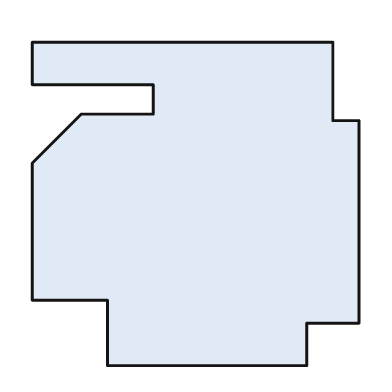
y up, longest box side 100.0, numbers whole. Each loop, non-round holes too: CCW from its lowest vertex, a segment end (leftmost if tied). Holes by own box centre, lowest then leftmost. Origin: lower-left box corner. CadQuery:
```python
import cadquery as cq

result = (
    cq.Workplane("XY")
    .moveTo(23.0, 0.0)
    .lineTo(84.0, 0.0)
    .lineTo(84.0, 13.0)
    .lineTo(100.0, 13.0)
    .lineTo(100.0, 75.0)
    .lineTo(92.0, 75.0)
    .lineTo(92.0, 99.0)
    .lineTo(0.0, 99.0)
    .lineTo(0.0, 86.0)
    .lineTo(37.0, 86.0)
    .lineTo(37.0, 77.0)
    .lineTo(15.0, 77.0)
    .lineTo(0.0, 62.0)
    .lineTo(0.0, 20.0)
    .lineTo(23.0, 20.0)
    .close()
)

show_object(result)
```